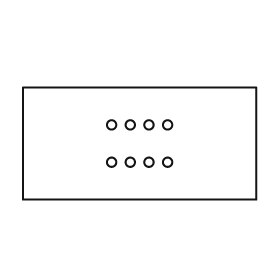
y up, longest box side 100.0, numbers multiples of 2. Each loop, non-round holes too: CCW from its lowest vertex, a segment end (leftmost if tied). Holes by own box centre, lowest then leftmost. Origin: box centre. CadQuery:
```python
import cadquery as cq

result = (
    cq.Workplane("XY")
    .moveTo(-50.0, -24.0)
    .lineTo(50.0, -24.0)
    .lineTo(50.0, 24.0)
    .lineTo(-50.0, 24.0)
    .close()
    .moveTo(-12.0, -8.0)
    .circle(2.0)
    .moveTo(-4.0, -8.0)
    .circle(2.0)
    .moveTo(4.0, -8.0)
    .circle(2.0)
    .moveTo(12.0, -8.0)
    .circle(2.0)
    .moveTo(-12.0, 8.0)
    .circle(2.0)
    .moveTo(-4.0, 8.0)
    .circle(2.0)
    .moveTo(4.0, 8.0)
    .circle(2.0)
    .moveTo(12.0, 8.0)
    .circle(2.0)
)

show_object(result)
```